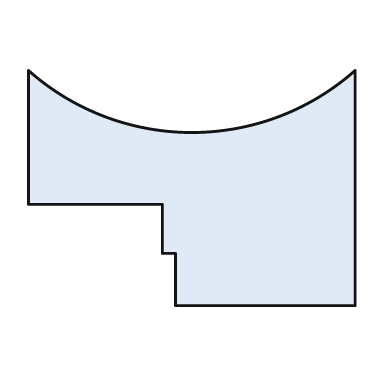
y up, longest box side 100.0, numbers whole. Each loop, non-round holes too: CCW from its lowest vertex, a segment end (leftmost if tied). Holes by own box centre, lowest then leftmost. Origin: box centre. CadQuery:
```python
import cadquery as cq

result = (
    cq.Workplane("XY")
    .moveTo(-5.0, -36.0)
    .lineTo(50.0, -36.0)
    .lineTo(50.0, 36.0)
    .threePointArc((0.0, 17.0), (-50.0, 36.0))
    .lineTo(-50.0, -5.0)
    .lineTo(-9.0, -5.0)
    .lineTo(-9.0, -20.0)
    .lineTo(-5.0, -20.0)
    .close()
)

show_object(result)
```